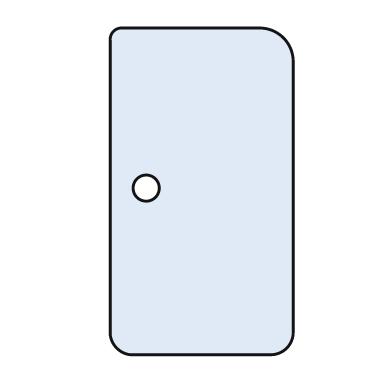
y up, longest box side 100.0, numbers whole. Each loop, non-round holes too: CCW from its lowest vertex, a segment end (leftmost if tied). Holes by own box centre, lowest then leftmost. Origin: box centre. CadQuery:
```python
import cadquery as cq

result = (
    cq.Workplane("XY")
    .moveTo(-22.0, -50.0)
    .lineTo(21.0, -50.0)
    .threePointArc((26.0, -48.0), (28.0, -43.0))
    .lineTo(28.0, 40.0)
    .threePointArc((25.0, 47.0), (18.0, 50.0))
    .lineTo(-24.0, 50.0)
    .threePointArc((-27.0, 49.0), (-28.0, 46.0))
    .lineTo(-28.0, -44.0)
    .threePointArc((-26.0, -48.0), (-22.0, -50.0))
    .close()
    .moveTo(-17.0, 1.0)
    .circle(4.0)
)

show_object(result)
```